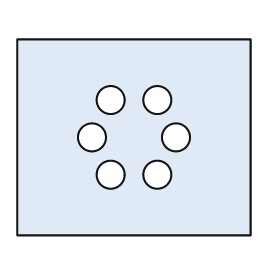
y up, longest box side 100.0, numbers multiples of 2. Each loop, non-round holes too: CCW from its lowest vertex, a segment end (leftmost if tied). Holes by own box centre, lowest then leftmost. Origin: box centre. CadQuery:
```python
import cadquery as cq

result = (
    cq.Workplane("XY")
    .moveTo(-50.0, -42.0)
    .lineTo(50.0, -42.0)
    .lineTo(50.0, 42.0)
    .lineTo(-50.0, 42.0)
    .close()
    .moveTo(-10.0, -16.0)
    .circle(6.0)
    .moveTo(10.0, -16.0)
    .circle(6.0)
    .moveTo(-18.0, 0.0)
    .circle(6.0)
    .moveTo(18.0, 0.0)
    .circle(6.0)
    .moveTo(-10.0, 16.0)
    .circle(6.0)
    .moveTo(10.0, 16.0)
    .circle(6.0)
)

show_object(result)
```